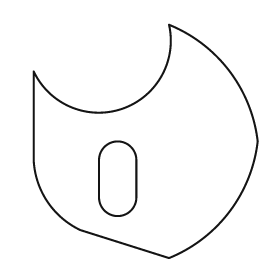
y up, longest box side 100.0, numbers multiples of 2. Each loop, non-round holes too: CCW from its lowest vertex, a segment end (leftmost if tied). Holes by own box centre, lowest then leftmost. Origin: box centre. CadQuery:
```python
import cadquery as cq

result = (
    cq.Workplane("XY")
    .moveTo(10.0, -50.0)
    .threePointArc((36.0, -30.0), (48.0, 0.0))
    .threePointArc((36.0, 30.0), (10.0, 50.0))
    .threePointArc((-10.0, 14.0), (-48.0, 30.0))
    .lineTo(-48.0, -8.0)
    .threePointArc((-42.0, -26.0), (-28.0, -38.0))
    .close()
    .moveTo(-20.0, -24.0)
    .threePointArc((-12.0, -32.0), (-4.0, -24.0))
    .lineTo(-4.0, -8.0)
    .threePointArc((-12.0, 0.0), (-20.0, -8.0))
    .close()
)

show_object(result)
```